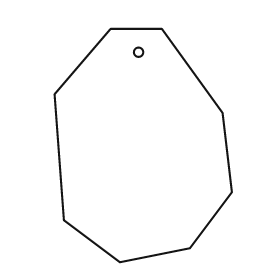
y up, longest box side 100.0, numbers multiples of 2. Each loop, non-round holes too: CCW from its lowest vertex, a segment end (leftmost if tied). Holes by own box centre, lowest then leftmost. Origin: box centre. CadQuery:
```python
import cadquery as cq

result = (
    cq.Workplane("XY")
    .moveTo(-10.0, -50.0)
    .lineTo(20.0, -44.0)
    .lineTo(38.0, -20.0)
    .lineTo(34.0, 14.0)
    .lineTo(8.0, 50.0)
    .lineTo(-14.0, 50.0)
    .lineTo(-38.0, 22.0)
    .lineTo(-34.0, -32.0)
    .close()
    .moveTo(-2.0, 40.0)
    .circle(2.0)
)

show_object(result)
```